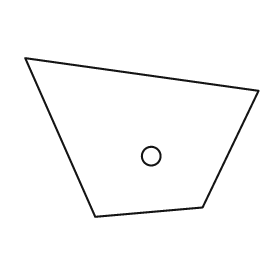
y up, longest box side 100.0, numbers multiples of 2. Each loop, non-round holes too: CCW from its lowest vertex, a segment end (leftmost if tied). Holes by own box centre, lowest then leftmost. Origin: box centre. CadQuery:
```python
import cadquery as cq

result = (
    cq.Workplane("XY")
    .moveTo(-20.0, -34.0)
    .lineTo(26.0, -30.0)
    .lineTo(50.0, 20.0)
    .lineTo(-50.0, 34.0)
    .close()
    .moveTo(4.0, -8.0)
    .circle(4.0)
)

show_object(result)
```